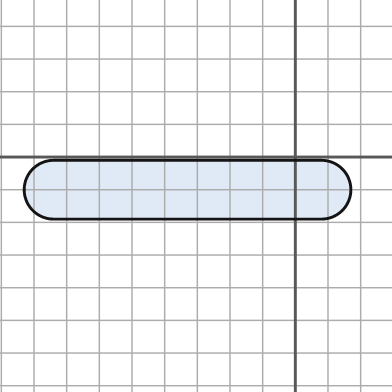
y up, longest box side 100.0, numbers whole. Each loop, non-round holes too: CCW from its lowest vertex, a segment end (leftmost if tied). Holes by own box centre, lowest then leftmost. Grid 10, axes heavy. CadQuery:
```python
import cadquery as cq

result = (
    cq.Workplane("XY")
    .moveTo(-74.0, -19.0)
    .lineTo(8.0, -19.0)
    .threePointArc((17.0, -10.0), (8.0, -1.0))
    .lineTo(-74.0, -1.0)
    .threePointArc((-83.0, -10.0), (-74.0, -19.0))
    .close()
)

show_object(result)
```